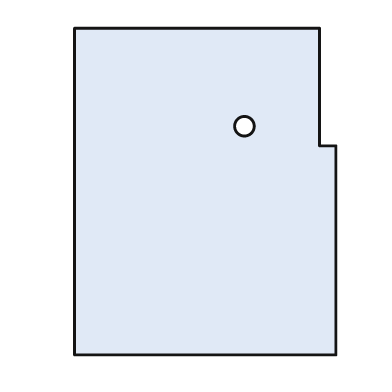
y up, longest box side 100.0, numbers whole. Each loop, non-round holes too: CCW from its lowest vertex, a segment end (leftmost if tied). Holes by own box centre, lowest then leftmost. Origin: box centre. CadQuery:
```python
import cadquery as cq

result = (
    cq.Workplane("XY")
    .moveTo(-40.0, -50.0)
    .lineTo(40.0, -50.0)
    .lineTo(40.0, 14.0)
    .lineTo(35.0, 14.0)
    .lineTo(35.0, 50.0)
    .lineTo(-40.0, 50.0)
    .close()
    .moveTo(12.0, 20.0)
    .circle(3.0)
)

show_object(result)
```